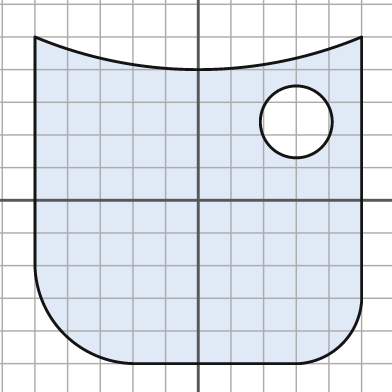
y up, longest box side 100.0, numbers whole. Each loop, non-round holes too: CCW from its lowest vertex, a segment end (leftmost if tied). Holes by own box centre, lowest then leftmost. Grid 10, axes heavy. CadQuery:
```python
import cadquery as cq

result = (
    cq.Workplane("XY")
    .moveTo(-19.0, -50.0)
    .lineTo(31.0, -50.0)
    .threePointArc((44.0, -44.0), (50.0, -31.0))
    .lineTo(50.0, 50.0)
    .threePointArc((0.0, 40.0), (-50.0, 50.0))
    .lineTo(-50.0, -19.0)
    .threePointArc((-41.0, -41.0), (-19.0, -50.0))
    .close()
    .moveTo(30.0, 24.0)
    .circle(11.0)
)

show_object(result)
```